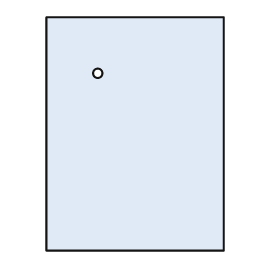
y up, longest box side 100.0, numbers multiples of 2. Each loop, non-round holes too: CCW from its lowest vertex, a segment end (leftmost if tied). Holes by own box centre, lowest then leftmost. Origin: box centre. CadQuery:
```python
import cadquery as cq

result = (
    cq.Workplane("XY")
    .moveTo(-38.0, -50.0)
    .lineTo(38.0, -50.0)
    .lineTo(38.0, 50.0)
    .lineTo(-38.0, 50.0)
    .close()
    .moveTo(-16.0, 26.0)
    .circle(2.0)
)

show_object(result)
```